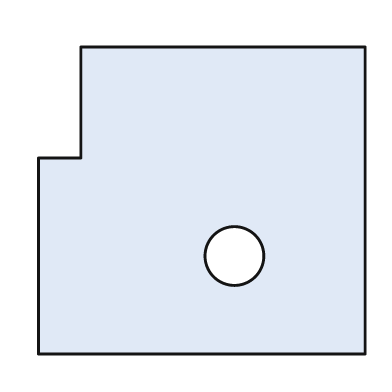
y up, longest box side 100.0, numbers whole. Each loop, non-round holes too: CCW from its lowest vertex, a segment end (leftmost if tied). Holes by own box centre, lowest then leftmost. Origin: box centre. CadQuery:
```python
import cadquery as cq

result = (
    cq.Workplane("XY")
    .moveTo(-50.0, -47.0)
    .lineTo(50.0, -47.0)
    .lineTo(50.0, 47.0)
    .lineTo(-37.0, 47.0)
    .lineTo(-37.0, 13.0)
    .lineTo(-50.0, 13.0)
    .close()
    .moveTo(10.0, -17.0)
    .circle(9.0)
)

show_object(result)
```